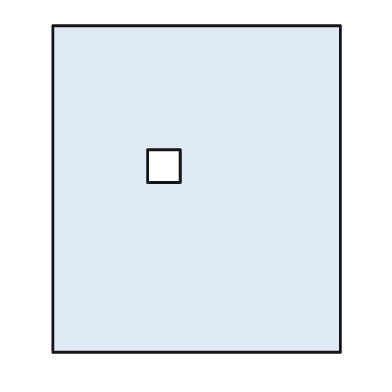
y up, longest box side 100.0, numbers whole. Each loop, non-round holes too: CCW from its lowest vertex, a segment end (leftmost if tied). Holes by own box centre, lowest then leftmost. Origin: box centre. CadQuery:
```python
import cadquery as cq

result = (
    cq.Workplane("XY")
    .moveTo(-44.0, -50.0)
    .lineTo(44.0, -50.0)
    .lineTo(44.0, 50.0)
    .lineTo(-44.0, 50.0)
    .close()
    .moveTo(-15.0, 2.0)
    .lineTo(-5.0, 2.0)
    .lineTo(-5.0, 12.0)
    .lineTo(-15.0, 12.0)
    .close()
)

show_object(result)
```